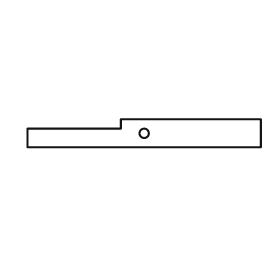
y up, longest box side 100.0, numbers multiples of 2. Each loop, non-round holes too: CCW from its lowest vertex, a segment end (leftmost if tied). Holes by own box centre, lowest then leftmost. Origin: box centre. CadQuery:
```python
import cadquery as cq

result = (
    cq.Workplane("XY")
    .moveTo(-50.0, -6.0)
    .lineTo(50.0, -6.0)
    .lineTo(50.0, 6.0)
    .lineTo(-10.0, 6.0)
    .lineTo(-10.0, 2.0)
    .lineTo(-50.0, 2.0)
    .close()
    .moveTo(0.0, 0.0)
    .circle(2.0)
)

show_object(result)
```